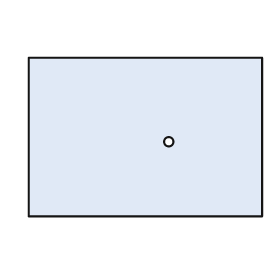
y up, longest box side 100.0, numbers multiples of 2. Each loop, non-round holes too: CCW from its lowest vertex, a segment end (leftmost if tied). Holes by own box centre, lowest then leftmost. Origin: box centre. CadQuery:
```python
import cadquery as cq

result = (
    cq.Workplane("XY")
    .moveTo(-50.0, -34.0)
    .lineTo(50.0, -34.0)
    .lineTo(50.0, 34.0)
    .lineTo(-50.0, 34.0)
    .close()
    .moveTo(10.0, -2.0)
    .circle(2.0)
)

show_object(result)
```